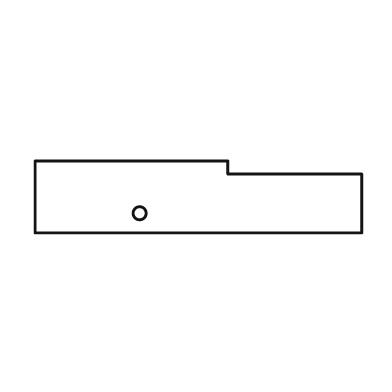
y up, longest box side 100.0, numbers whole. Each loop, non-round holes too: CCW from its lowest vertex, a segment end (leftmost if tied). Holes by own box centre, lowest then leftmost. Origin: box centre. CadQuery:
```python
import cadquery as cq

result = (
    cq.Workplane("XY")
    .moveTo(-50.0, -11.0)
    .lineTo(50.0, -11.0)
    .lineTo(50.0, 7.0)
    .lineTo(9.0, 7.0)
    .lineTo(9.0, 11.0)
    .lineTo(-50.0, 11.0)
    .close()
    .moveTo(-18.0, -5.0)
    .circle(2.0)
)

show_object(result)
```